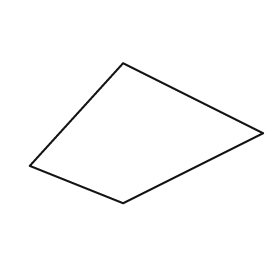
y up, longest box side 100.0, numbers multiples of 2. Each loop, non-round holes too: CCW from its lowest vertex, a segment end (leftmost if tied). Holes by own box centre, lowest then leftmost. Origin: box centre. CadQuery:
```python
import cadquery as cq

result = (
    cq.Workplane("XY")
    .moveTo(-10.0, -30.0)
    .lineTo(50.0, 0.0)
    .lineTo(-10.0, 30.0)
    .lineTo(-50.0, -14.0)
    .close()
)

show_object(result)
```